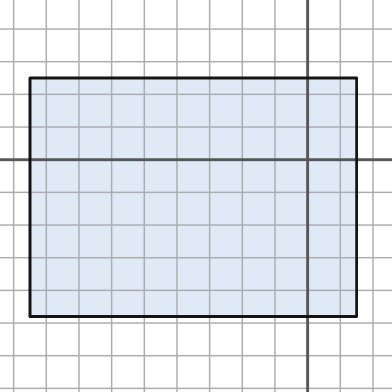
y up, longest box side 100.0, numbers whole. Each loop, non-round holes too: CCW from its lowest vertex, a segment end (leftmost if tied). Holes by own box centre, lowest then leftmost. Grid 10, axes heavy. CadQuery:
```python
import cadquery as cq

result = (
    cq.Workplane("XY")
    .moveTo(-85.0, -48.0)
    .lineTo(15.0, -48.0)
    .lineTo(15.0, 25.0)
    .lineTo(-85.0, 25.0)
    .close()
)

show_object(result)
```